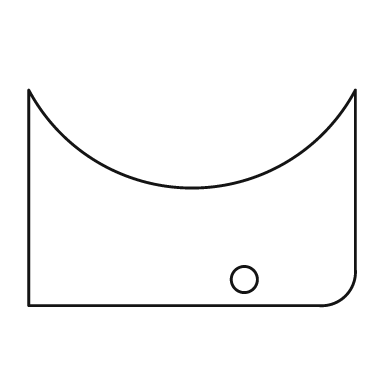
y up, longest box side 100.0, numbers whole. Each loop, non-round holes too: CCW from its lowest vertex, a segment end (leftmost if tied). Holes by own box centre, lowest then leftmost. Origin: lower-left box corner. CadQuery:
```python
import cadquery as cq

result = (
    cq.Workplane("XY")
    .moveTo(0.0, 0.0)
    .lineTo(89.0, 0.0)
    .threePointArc((97.0, 3.0), (100.0, 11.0))
    .lineTo(100.0, 66.0)
    .threePointArc((50.0, 36.0), (0.0, 66.0))
    .close()
    .moveTo(66.0, 8.0)
    .circle(4.0)
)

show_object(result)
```